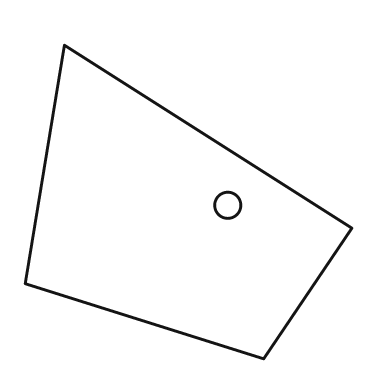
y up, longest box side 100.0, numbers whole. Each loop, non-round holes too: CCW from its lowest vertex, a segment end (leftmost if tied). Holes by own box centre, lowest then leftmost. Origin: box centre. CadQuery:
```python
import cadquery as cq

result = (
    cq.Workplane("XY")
    .moveTo(23.0, -48.0)
    .lineTo(50.0, -8.0)
    .lineTo(-38.0, 48.0)
    .lineTo(-50.0, -25.0)
    .close()
    .moveTo(12.0, -1.0)
    .circle(4.0)
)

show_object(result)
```